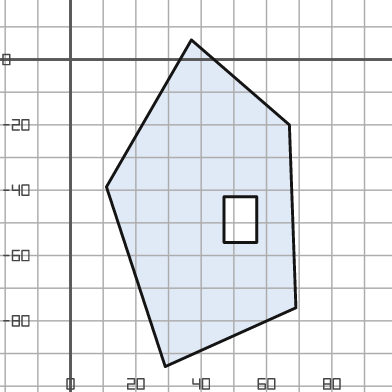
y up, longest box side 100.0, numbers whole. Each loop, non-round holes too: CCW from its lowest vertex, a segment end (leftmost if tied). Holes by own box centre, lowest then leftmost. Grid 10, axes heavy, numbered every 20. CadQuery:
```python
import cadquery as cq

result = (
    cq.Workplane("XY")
    .moveTo(29.0, -94.0)
    .lineTo(69.0, -76.0)
    .lineTo(67.0, -20.0)
    .lineTo(37.0, 6.0)
    .lineTo(11.0, -39.0)
    .close()
    .moveTo(47.0, -56.0)
    .lineTo(57.0, -56.0)
    .lineTo(57.0, -42.0)
    .lineTo(47.0, -42.0)
    .close()
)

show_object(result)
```